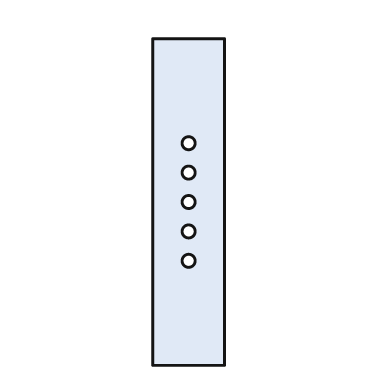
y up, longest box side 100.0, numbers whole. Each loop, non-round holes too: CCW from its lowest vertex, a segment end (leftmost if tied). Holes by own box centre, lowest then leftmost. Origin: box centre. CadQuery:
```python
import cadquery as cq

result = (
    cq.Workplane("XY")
    .moveTo(-11.0, -50.0)
    .lineTo(11.0, -50.0)
    .lineTo(11.0, 50.0)
    .lineTo(-11.0, 50.0)
    .close()
    .moveTo(0.0, -18.0)
    .circle(2.0)
    .moveTo(0.0, -9.0)
    .circle(2.0)
    .moveTo(0.0, 0.0)
    .circle(2.0)
    .moveTo(0.0, 9.0)
    .circle(2.0)
    .moveTo(0.0, 18.0)
    .circle(2.0)
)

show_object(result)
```